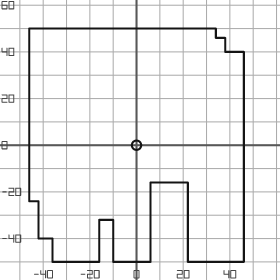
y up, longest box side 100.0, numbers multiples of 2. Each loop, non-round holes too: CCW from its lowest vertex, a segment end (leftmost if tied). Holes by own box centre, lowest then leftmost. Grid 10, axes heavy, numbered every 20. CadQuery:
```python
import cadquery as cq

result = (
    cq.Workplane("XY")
    .moveTo(-36.0, -50.0)
    .lineTo(-16.0, -50.0)
    .lineTo(-16.0, -32.0)
    .lineTo(-10.0, -32.0)
    .lineTo(-10.0, -50.0)
    .lineTo(6.0, -50.0)
    .lineTo(6.0, -16.0)
    .lineTo(22.0, -16.0)
    .lineTo(22.0, -50.0)
    .lineTo(46.0, -50.0)
    .lineTo(46.0, 40.0)
    .lineTo(38.0, 40.0)
    .lineTo(38.0, 46.0)
    .lineTo(34.0, 46.0)
    .lineTo(34.0, 50.0)
    .lineTo(-46.0, 50.0)
    .lineTo(-46.0, -24.0)
    .lineTo(-42.0, -24.0)
    .lineTo(-42.0, -40.0)
    .lineTo(-36.0, -40.0)
    .close()
    .moveTo(0.0, 0.0)
    .circle(2.0)
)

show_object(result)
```